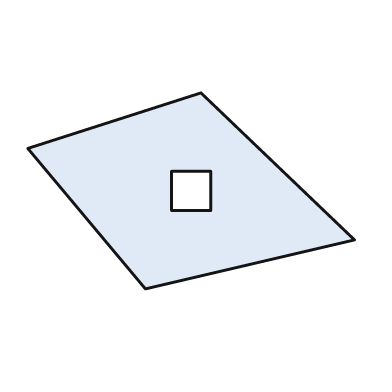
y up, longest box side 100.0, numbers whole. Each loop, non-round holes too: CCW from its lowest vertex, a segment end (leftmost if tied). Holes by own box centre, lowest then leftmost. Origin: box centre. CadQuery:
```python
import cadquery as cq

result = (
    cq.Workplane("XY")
    .moveTo(-14.0, -30.0)
    .lineTo(50.0, -15.0)
    .lineTo(3.0, 30.0)
    .lineTo(-50.0, 13.0)
    .close()
    .moveTo(-6.0, -6.0)
    .lineTo(6.0, -6.0)
    .lineTo(6.0, 6.0)
    .lineTo(-6.0, 6.0)
    .close()
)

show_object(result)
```